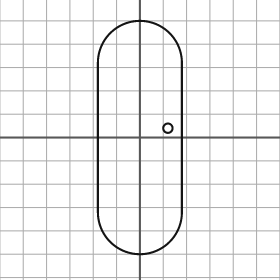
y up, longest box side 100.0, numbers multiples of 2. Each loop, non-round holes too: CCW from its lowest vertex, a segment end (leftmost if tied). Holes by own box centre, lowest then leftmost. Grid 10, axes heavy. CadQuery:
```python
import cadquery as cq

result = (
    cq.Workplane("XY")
    .moveTo(-18.0, -32.0)
    .threePointArc((0.0, -50.0), (18.0, -32.0))
    .lineTo(18.0, 32.0)
    .threePointArc((0.0, 50.0), (-18.0, 32.0))
    .close()
    .moveTo(12.0, 4.0)
    .circle(2.0)
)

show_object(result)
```